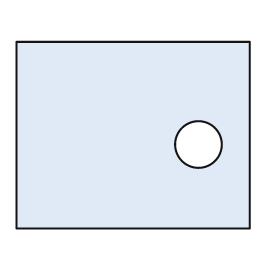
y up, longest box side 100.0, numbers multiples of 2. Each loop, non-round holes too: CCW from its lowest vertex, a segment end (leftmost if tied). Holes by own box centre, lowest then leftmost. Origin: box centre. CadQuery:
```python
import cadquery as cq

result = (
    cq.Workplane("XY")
    .moveTo(-50.0, -40.0)
    .lineTo(50.0, -40.0)
    .lineTo(50.0, 40.0)
    .lineTo(-50.0, 40.0)
    .close()
    .moveTo(28.0, -4.0)
    .circle(10.0)
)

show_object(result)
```